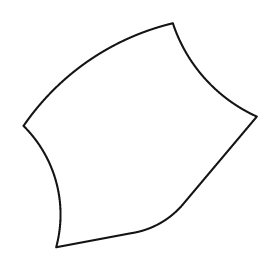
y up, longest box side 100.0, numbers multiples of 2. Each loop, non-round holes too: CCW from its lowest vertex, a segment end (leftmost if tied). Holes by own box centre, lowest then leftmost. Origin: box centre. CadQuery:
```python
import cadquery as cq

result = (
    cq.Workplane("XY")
    .moveTo(-36.0, -48.0)
    .lineTo(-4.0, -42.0)
    .threePointArc((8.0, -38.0), (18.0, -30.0))
    .lineTo(50.0, 8.0)
    .threePointArc((28.0, 24.0), (14.0, 48.0))
    .threePointArc((-22.0, 32.0), (-50.0, 4.0))
    .threePointArc((-36.0, -20.0), (-36.0, -48.0))
    .close()
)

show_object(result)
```